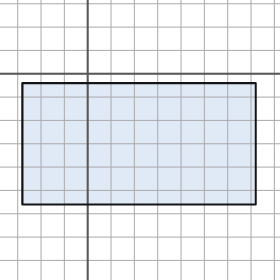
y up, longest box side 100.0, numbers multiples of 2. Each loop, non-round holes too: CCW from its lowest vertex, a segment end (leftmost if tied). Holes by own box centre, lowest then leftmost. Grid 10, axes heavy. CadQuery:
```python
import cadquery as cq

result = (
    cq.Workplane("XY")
    .moveTo(-28.0, -56.0)
    .lineTo(72.0, -56.0)
    .lineTo(72.0, -4.0)
    .lineTo(-28.0, -4.0)
    .close()
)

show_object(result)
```